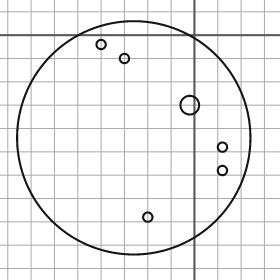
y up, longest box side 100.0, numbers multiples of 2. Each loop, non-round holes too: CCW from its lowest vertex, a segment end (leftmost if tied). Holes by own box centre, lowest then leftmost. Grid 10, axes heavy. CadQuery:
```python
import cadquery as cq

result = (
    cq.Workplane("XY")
    .moveTo(-26.0, -44.0)
    .circle(50.0)
    .moveTo(-20.0, -78.0)
    .circle(2.0)
    .moveTo(12.0, -58.0)
    .circle(2.0)
    .moveTo(12.0, -48.0)
    .circle(2.0)
    .moveTo(-2.0, -30.0)
    .circle(4.0)
    .moveTo(-30.0, -10.0)
    .circle(2.0)
    .moveTo(-40.0, -4.0)
    .circle(2.0)
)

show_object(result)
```